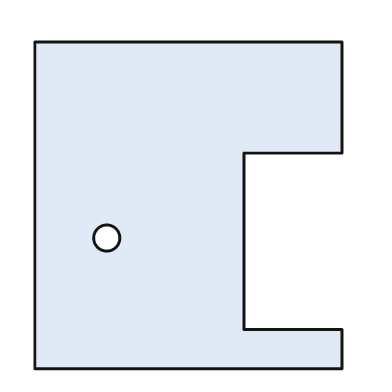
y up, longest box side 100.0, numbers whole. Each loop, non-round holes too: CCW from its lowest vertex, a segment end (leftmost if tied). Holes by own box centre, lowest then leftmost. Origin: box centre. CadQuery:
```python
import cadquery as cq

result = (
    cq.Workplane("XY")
    .moveTo(-47.0, -50.0)
    .lineTo(47.0, -50.0)
    .lineTo(47.0, -38.0)
    .lineTo(17.0, -38.0)
    .lineTo(17.0, 16.0)
    .lineTo(47.0, 16.0)
    .lineTo(47.0, 50.0)
    .lineTo(-47.0, 50.0)
    .close()
    .moveTo(-25.0, -10.0)
    .circle(4.0)
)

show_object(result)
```